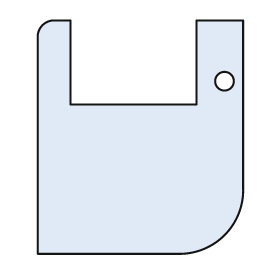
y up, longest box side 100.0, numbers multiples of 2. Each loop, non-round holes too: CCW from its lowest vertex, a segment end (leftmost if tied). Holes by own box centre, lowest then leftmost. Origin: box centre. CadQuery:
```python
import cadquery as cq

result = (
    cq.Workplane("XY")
    .moveTo(-44.0, -50.0)
    .lineTo(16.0, -50.0)
    .threePointArc((36.0, -42.0), (44.0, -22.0))
    .lineTo(44.0, 50.0)
    .lineTo(24.0, 50.0)
    .lineTo(24.0, 14.0)
    .lineTo(-30.0, 14.0)
    .lineTo(-30.0, 50.0)
    .lineTo(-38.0, 50.0)
    .threePointArc((-42.0, 48.0), (-44.0, 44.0))
    .close()
    .moveTo(36.0, 24.0)
    .circle(4.0)
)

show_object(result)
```